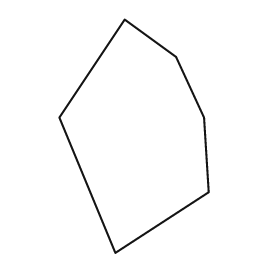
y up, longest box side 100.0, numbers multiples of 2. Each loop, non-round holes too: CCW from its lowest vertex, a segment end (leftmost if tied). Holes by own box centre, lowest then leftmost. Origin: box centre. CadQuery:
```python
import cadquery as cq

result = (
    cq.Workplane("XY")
    .moveTo(-8.0, -50.0)
    .lineTo(32.0, -24.0)
    .lineTo(30.0, 8.0)
    .lineTo(18.0, 34.0)
    .lineTo(-4.0, 50.0)
    .lineTo(-32.0, 8.0)
    .close()
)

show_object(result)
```